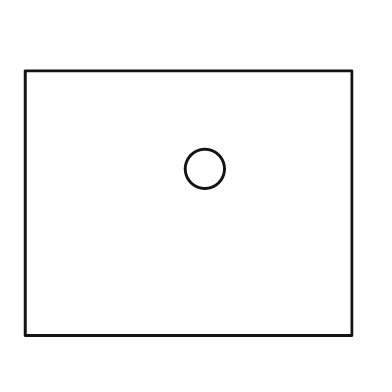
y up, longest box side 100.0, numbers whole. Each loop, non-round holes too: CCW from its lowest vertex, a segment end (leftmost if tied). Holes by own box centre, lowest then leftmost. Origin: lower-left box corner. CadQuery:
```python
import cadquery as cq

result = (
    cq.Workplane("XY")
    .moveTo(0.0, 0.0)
    .lineTo(100.0, 0.0)
    .lineTo(100.0, 81.0)
    .lineTo(0.0, 81.0)
    .close()
    .moveTo(55.0, 51.0)
    .circle(6.0)
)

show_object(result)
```